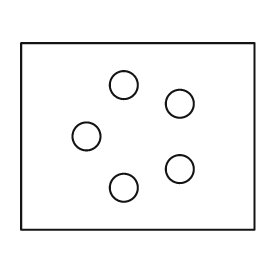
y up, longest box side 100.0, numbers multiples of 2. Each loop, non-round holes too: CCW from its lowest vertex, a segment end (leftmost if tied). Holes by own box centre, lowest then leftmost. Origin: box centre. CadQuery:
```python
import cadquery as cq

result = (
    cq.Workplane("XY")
    .moveTo(-50.0, -40.0)
    .lineTo(50.0, -40.0)
    .lineTo(50.0, 40.0)
    .lineTo(-50.0, 40.0)
    .close()
    .moveTo(-6.0, -22.0)
    .circle(6.0)
    .moveTo(18.0, -14.0)
    .circle(6.0)
    .moveTo(-22.0, 0.0)
    .circle(6.0)
    .moveTo(18.0, 14.0)
    .circle(6.0)
    .moveTo(-6.0, 22.0)
    .circle(6.0)
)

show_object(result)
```